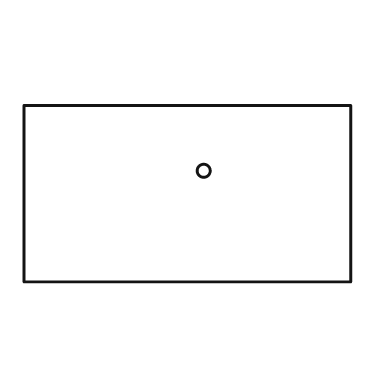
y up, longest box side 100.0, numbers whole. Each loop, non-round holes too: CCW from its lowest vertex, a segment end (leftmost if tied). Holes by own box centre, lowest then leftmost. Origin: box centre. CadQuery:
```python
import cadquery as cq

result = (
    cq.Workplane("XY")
    .moveTo(-50.0, -27.0)
    .lineTo(50.0, -27.0)
    .lineTo(50.0, 27.0)
    .lineTo(-50.0, 27.0)
    .close()
    .moveTo(5.0, 7.0)
    .circle(2.0)
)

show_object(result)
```